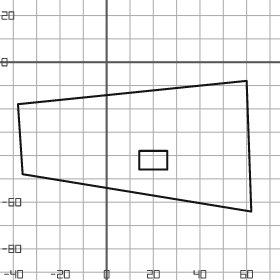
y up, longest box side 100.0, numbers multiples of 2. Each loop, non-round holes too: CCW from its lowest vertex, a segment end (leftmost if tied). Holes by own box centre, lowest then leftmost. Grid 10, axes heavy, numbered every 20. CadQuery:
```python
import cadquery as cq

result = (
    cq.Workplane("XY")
    .moveTo(62.0, -64.0)
    .lineTo(60.0, -8.0)
    .lineTo(-38.0, -18.0)
    .lineTo(-36.0, -48.0)
    .close()
    .moveTo(14.0, -46.0)
    .lineTo(26.0, -46.0)
    .lineTo(26.0, -38.0)
    .lineTo(14.0, -38.0)
    .close()
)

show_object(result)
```